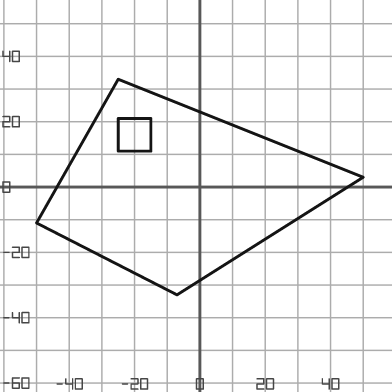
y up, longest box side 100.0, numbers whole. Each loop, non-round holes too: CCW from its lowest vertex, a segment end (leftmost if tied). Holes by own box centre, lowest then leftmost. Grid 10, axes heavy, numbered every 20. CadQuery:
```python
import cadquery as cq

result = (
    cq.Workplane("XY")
    .moveTo(-7.0, -33.0)
    .lineTo(50.0, 3.0)
    .lineTo(-25.0, 33.0)
    .lineTo(-50.0, -11.0)
    .close()
    .moveTo(-25.0, 11.0)
    .lineTo(-15.0, 11.0)
    .lineTo(-15.0, 21.0)
    .lineTo(-25.0, 21.0)
    .close()
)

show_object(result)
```